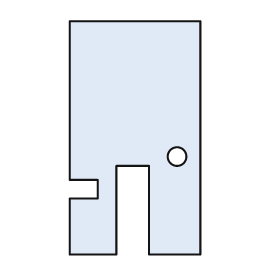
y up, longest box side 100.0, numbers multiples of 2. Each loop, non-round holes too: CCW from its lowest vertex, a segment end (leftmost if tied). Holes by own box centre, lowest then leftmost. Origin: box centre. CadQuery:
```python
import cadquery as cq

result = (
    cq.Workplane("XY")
    .moveTo(-28.0, -50.0)
    .lineTo(-8.0, -50.0)
    .lineTo(-8.0, -12.0)
    .lineTo(6.0, -12.0)
    .lineTo(6.0, -50.0)
    .lineTo(28.0, -50.0)
    .lineTo(28.0, 50.0)
    .lineTo(-28.0, 50.0)
    .lineTo(-28.0, -18.0)
    .lineTo(-16.0, -18.0)
    .lineTo(-16.0, -26.0)
    .lineTo(-28.0, -26.0)
    .close()
    .moveTo(18.0, -8.0)
    .circle(4.0)
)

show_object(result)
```